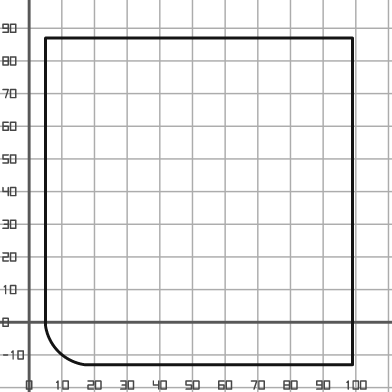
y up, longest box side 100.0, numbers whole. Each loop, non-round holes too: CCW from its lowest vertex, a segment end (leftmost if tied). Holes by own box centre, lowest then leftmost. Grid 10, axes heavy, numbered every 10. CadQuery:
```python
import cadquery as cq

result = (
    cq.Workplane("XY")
    .moveTo(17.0, -13.0)
    .lineTo(99.0, -13.0)
    .lineTo(99.0, 87.0)
    .lineTo(5.0, 87.0)
    .lineTo(5.0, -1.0)
    .threePointArc((9.0, -9.0), (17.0, -13.0))
    .close()
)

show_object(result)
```